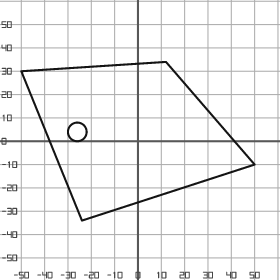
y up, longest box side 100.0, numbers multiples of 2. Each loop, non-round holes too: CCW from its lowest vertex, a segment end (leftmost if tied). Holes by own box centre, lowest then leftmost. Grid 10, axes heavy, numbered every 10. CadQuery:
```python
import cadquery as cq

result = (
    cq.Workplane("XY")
    .moveTo(-24.0, -34.0)
    .lineTo(50.0, -10.0)
    .lineTo(12.0, 34.0)
    .lineTo(-50.0, 30.0)
    .close()
    .moveTo(-26.0, 4.0)
    .circle(4.0)
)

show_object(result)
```